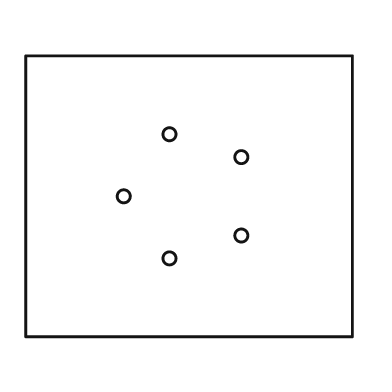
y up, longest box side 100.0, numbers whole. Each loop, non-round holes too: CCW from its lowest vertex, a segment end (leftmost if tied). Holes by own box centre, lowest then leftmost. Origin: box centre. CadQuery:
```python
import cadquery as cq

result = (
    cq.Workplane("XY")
    .moveTo(-50.0, -43.0)
    .lineTo(50.0, -43.0)
    .lineTo(50.0, 43.0)
    .lineTo(-50.0, 43.0)
    .close()
    .moveTo(-6.0, -19.0)
    .circle(2.0)
    .moveTo(16.0, -12.0)
    .circle(2.0)
    .moveTo(-20.0, 0.0)
    .circle(2.0)
    .moveTo(16.0, 12.0)
    .circle(2.0)
    .moveTo(-6.0, 19.0)
    .circle(2.0)
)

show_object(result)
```